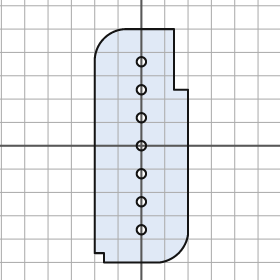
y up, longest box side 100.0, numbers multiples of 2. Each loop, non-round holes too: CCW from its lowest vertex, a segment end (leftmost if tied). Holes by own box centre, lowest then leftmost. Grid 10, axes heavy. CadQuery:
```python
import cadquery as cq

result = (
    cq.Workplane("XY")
    .moveTo(-16.0, -50.0)
    .lineTo(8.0, -50.0)
    .threePointArc((16.0, -46.0), (20.0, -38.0))
    .lineTo(20.0, 24.0)
    .lineTo(14.0, 24.0)
    .lineTo(14.0, 50.0)
    .lineTo(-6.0, 50.0)
    .threePointArc((-16.0, 46.0), (-20.0, 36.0))
    .lineTo(-20.0, -46.0)
    .lineTo(-16.0, -46.0)
    .close()
    .moveTo(0.0, -36.0)
    .circle(2.0)
    .moveTo(0.0, -24.0)
    .circle(2.0)
    .moveTo(0.0, -12.0)
    .circle(2.0)
    .moveTo(0.0, 0.0)
    .circle(2.0)
    .moveTo(0.0, 12.0)
    .circle(2.0)
    .moveTo(0.0, 24.0)
    .circle(2.0)
    .moveTo(0.0, 36.0)
    .circle(2.0)
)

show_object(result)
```